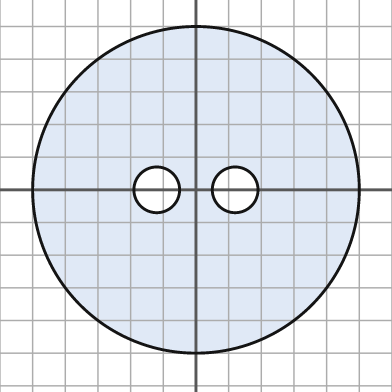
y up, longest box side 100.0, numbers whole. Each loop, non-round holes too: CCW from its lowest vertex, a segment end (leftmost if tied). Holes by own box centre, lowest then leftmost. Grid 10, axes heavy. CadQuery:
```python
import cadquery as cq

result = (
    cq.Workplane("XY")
    .moveTo(0.0, 0.0)
    .circle(50.0)
    .moveTo(-12.0, 0.0)
    .circle(7.0)
    .moveTo(12.0, 0.0)
    .circle(7.0)
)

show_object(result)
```